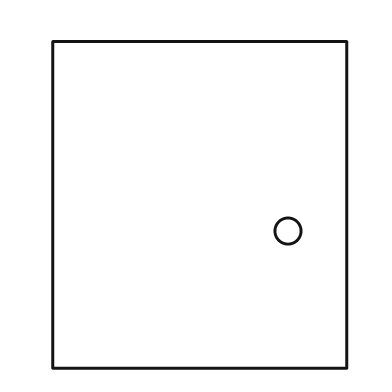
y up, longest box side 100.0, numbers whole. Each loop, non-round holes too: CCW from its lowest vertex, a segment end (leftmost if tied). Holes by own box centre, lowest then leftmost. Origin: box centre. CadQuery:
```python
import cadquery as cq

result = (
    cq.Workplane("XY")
    .moveTo(-45.0, -50.0)
    .lineTo(45.0, -50.0)
    .lineTo(45.0, 50.0)
    .lineTo(-45.0, 50.0)
    .close()
    .moveTo(27.0, -8.0)
    .circle(4.0)
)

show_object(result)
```